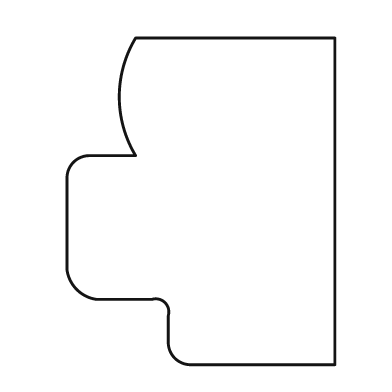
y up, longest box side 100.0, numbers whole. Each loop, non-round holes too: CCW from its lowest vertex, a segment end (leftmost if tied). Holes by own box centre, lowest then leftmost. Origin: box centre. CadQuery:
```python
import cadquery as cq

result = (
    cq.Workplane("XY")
    .moveTo(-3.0, -50.0)
    .lineTo(41.0, -50.0)
    .lineTo(41.0, 50.0)
    .lineTo(-20.0, 50.0)
    .threePointArc((-25.0, 32.0), (-20.0, 14.0))
    .lineTo(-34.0, 14.0)
    .threePointArc((-39.0, 12.0), (-41.0, 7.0))
    .lineTo(-41.0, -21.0)
    .threePointArc((-38.0, -27.0), (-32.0, -30.0))
    .lineTo(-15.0, -30.0)
    .threePointArc((-11.0, -31.0), (-10.0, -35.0))
    .lineTo(-10.0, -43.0)
    .threePointArc((-8.0, -48.0), (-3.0, -50.0))
    .close()
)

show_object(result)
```